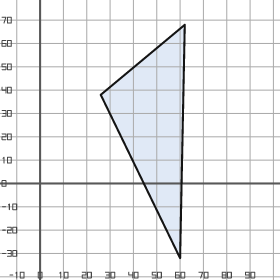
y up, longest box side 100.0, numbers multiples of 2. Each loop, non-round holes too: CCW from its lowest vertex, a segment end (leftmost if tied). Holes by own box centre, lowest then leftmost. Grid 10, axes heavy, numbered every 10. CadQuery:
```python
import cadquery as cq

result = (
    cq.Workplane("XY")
    .moveTo(60.0, -32.0)
    .lineTo(62.0, 68.0)
    .lineTo(26.0, 38.0)
    .close()
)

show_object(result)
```